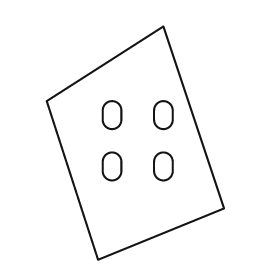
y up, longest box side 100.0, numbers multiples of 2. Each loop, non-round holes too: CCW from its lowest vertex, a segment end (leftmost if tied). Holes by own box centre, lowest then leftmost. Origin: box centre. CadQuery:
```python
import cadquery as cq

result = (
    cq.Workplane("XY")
    .moveTo(-16.0, -50.0)
    .lineTo(38.0, -28.0)
    .lineTo(12.0, 50.0)
    .lineTo(-38.0, 18.0)
    .close()
    .moveTo(-14.0, -12.0)
    .threePointArc((-10.0, -16.0), (-6.0, -12.0))
    .lineTo(-6.0, -8.0)
    .threePointArc((-10.0, -4.0), (-14.0, -8.0))
    .close()
    .moveTo(8.0, -12.0)
    .threePointArc((12.0, -16.0), (16.0, -12.0))
    .lineTo(16.0, -8.0)
    .threePointArc((12.0, -4.0), (8.0, -8.0))
    .close()
    .moveTo(-14.0, 10.0)
    .threePointArc((-10.0, 6.0), (-6.0, 10.0))
    .lineTo(-6.0, 14.0)
    .threePointArc((-10.0, 18.0), (-14.0, 14.0))
    .close()
    .moveTo(8.0, 10.0)
    .threePointArc((12.0, 6.0), (16.0, 10.0))
    .lineTo(16.0, 14.0)
    .threePointArc((12.0, 18.0), (8.0, 14.0))
    .close()
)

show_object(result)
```